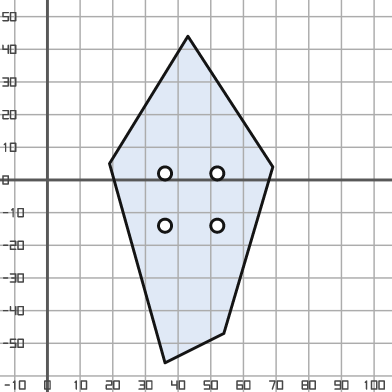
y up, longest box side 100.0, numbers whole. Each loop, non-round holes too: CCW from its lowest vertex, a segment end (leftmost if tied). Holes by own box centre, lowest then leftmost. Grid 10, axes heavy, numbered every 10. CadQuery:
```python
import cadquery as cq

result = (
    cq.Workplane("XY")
    .moveTo(36.0, -56.0)
    .lineTo(54.0, -47.0)
    .lineTo(69.0, 4.0)
    .lineTo(43.0, 44.0)
    .lineTo(19.0, 5.0)
    .close()
    .moveTo(36.0, -14.0)
    .circle(2.0)
    .moveTo(52.0, -14.0)
    .circle(2.0)
    .moveTo(36.0, 2.0)
    .circle(2.0)
    .moveTo(52.0, 2.0)
    .circle(2.0)
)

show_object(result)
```